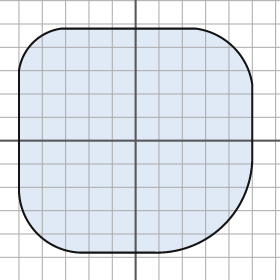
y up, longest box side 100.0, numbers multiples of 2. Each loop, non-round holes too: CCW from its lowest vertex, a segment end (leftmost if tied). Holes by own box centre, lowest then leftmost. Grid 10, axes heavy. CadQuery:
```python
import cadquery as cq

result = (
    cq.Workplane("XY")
    .moveTo(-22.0, -48.0)
    .lineTo(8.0, -48.0)
    .threePointArc((38.0, -36.0), (50.0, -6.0))
    .lineTo(50.0, 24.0)
    .threePointArc((42.0, 40.0), (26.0, 48.0))
    .lineTo(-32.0, 48.0)
    .threePointArc((-44.0, 42.0), (-50.0, 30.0))
    .lineTo(-50.0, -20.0)
    .threePointArc((-42.0, -40.0), (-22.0, -48.0))
    .close()
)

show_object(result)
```